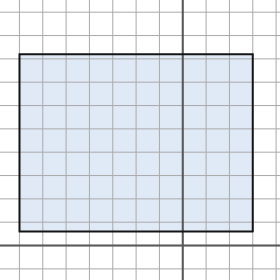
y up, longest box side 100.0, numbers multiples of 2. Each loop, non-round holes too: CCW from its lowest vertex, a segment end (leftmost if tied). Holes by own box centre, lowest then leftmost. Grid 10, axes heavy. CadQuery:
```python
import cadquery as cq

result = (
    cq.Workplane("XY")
    .moveTo(-70.0, 6.0)
    .lineTo(30.0, 6.0)
    .lineTo(30.0, 82.0)
    .lineTo(-70.0, 82.0)
    .close()
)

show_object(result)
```